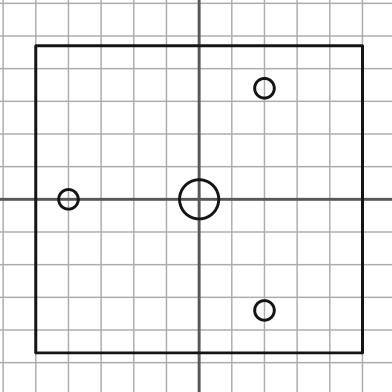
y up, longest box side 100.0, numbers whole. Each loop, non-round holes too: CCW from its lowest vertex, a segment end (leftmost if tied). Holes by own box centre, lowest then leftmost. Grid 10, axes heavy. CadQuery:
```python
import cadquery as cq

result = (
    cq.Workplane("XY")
    .moveTo(-50.0, -47.0)
    .lineTo(50.0, -47.0)
    .lineTo(50.0, 47.0)
    .lineTo(-50.0, 47.0)
    .close()
    .moveTo(20.0, -34.0)
    .circle(3.0)
    .moveTo(-40.0, 0.0)
    .circle(3.0)
    .moveTo(0.0, 0.0)
    .circle(6.0)
    .moveTo(20.0, 34.0)
    .circle(3.0)
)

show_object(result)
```